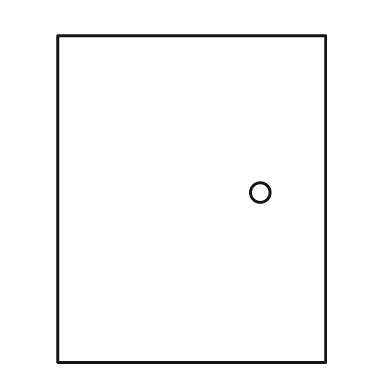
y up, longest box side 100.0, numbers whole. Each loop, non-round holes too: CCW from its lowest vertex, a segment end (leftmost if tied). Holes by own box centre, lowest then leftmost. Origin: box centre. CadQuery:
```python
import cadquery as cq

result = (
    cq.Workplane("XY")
    .moveTo(-41.0, -50.0)
    .lineTo(41.0, -50.0)
    .lineTo(41.0, 50.0)
    .lineTo(-41.0, 50.0)
    .close()
    .moveTo(21.0, 2.0)
    .circle(3.0)
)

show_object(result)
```